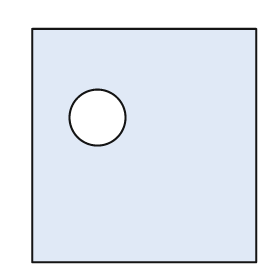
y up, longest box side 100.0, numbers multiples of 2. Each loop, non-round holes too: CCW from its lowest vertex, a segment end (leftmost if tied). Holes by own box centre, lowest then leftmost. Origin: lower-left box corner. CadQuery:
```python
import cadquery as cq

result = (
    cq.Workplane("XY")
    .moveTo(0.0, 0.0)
    .lineTo(96.0, 0.0)
    .lineTo(96.0, 100.0)
    .lineTo(0.0, 100.0)
    .close()
    .moveTo(28.0, 62.0)
    .circle(12.0)
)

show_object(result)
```